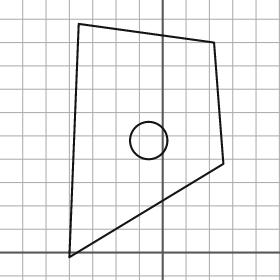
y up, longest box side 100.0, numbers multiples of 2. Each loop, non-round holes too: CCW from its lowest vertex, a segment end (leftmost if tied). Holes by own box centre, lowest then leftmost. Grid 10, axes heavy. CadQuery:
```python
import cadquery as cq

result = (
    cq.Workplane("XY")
    .moveTo(-40.0, -2.0)
    .lineTo(26.0, 38.0)
    .lineTo(22.0, 90.0)
    .lineTo(-36.0, 98.0)
    .close()
    .moveTo(-6.0, 48.0)
    .circle(8.0)
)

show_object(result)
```